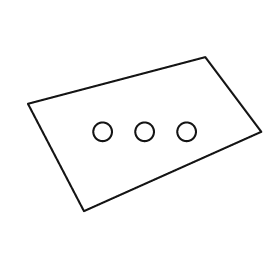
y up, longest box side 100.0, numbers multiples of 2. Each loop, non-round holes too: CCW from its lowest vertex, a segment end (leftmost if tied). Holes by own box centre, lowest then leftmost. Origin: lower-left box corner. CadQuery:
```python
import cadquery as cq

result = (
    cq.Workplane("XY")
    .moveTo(24.0, 0.0)
    .lineTo(100.0, 34.0)
    .lineTo(76.0, 66.0)
    .lineTo(0.0, 46.0)
    .close()
    .moveTo(32.0, 34.0)
    .circle(4.0)
    .moveTo(50.0, 34.0)
    .circle(4.0)
    .moveTo(68.0, 34.0)
    .circle(4.0)
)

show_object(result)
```